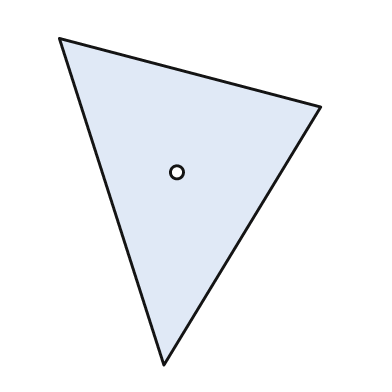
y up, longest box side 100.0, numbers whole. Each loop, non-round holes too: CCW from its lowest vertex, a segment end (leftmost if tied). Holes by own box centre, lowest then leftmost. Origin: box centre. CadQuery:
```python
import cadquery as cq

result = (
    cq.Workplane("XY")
    .moveTo(-8.0, -50.0)
    .lineTo(40.0, 29.0)
    .lineTo(-40.0, 50.0)
    .close()
    .moveTo(-4.0, 9.0)
    .circle(2.0)
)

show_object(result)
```